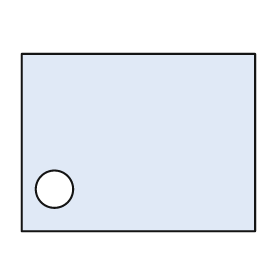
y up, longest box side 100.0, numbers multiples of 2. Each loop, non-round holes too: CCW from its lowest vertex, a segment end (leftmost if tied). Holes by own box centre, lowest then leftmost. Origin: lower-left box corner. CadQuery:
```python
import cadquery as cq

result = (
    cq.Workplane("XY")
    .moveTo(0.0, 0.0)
    .lineTo(100.0, 0.0)
    .lineTo(100.0, 76.0)
    .lineTo(0.0, 76.0)
    .close()
    .moveTo(14.0, 18.0)
    .circle(8.0)
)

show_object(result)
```